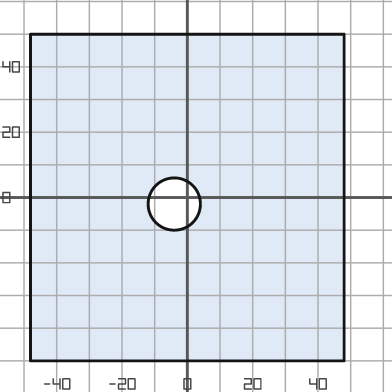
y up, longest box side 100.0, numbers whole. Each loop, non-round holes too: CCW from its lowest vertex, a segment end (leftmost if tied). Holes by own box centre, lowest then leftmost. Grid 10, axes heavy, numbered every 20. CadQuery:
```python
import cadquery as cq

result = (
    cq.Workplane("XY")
    .moveTo(-48.0, -50.0)
    .lineTo(48.0, -50.0)
    .lineTo(48.0, 50.0)
    .lineTo(-48.0, 50.0)
    .close()
    .moveTo(-4.0, -2.0)
    .circle(8.0)
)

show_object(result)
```